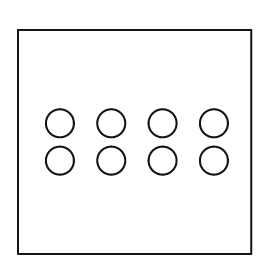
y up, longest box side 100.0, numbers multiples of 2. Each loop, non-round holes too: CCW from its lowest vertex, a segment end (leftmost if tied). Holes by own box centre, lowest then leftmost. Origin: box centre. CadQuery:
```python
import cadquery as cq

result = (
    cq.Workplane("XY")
    .moveTo(-50.0, -48.0)
    .lineTo(50.0, -48.0)
    .lineTo(50.0, 48.0)
    .lineTo(-50.0, 48.0)
    .close()
    .moveTo(-32.0, -8.0)
    .circle(6.0)
    .moveTo(-10.0, -8.0)
    .circle(6.0)
    .moveTo(12.0, -8.0)
    .circle(6.0)
    .moveTo(34.0, -8.0)
    .circle(6.0)
    .moveTo(-32.0, 8.0)
    .circle(6.0)
    .moveTo(-10.0, 8.0)
    .circle(6.0)
    .moveTo(12.0, 8.0)
    .circle(6.0)
    .moveTo(34.0, 8.0)
    .circle(6.0)
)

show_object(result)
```